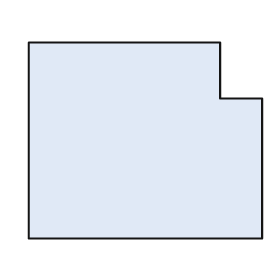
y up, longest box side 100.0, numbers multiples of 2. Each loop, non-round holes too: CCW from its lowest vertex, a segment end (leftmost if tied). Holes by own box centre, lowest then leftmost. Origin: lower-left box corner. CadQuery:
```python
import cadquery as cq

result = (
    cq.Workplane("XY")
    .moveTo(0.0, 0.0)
    .lineTo(100.0, 0.0)
    .lineTo(100.0, 60.0)
    .lineTo(82.0, 60.0)
    .lineTo(82.0, 84.0)
    .lineTo(0.0, 84.0)
    .close()
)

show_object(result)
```